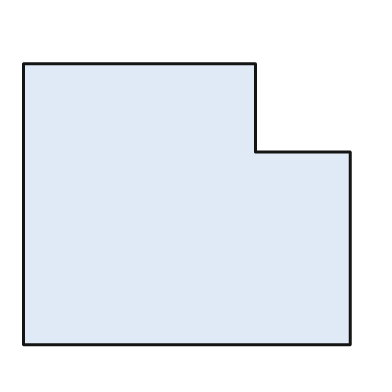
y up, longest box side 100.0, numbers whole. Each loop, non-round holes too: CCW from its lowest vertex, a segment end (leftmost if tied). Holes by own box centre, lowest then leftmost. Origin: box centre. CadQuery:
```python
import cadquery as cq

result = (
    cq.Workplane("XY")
    .moveTo(-50.0, -43.0)
    .lineTo(50.0, -43.0)
    .lineTo(50.0, 16.0)
    .lineTo(21.0, 16.0)
    .lineTo(21.0, 43.0)
    .lineTo(-50.0, 43.0)
    .close()
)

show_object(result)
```